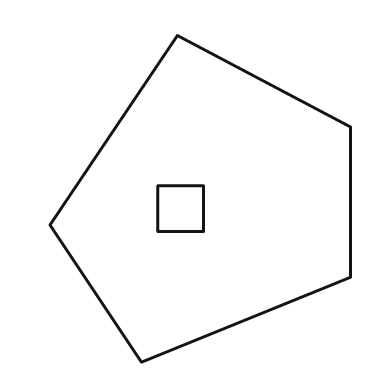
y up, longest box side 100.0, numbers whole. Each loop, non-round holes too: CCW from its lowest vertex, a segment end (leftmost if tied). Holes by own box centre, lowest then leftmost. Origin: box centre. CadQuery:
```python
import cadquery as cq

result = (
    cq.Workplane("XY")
    .moveTo(-18.0, -50.0)
    .lineTo(46.0, -24.0)
    .lineTo(46.0, 22.0)
    .lineTo(-7.0, 50.0)
    .lineTo(-46.0, -8.0)
    .close()
    .moveTo(-13.0, -10.0)
    .lineTo(1.0, -10.0)
    .lineTo(1.0, 4.0)
    .lineTo(-13.0, 4.0)
    .close()
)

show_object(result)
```